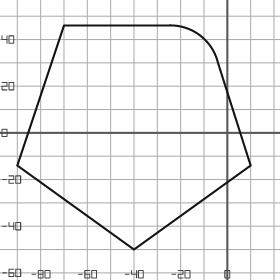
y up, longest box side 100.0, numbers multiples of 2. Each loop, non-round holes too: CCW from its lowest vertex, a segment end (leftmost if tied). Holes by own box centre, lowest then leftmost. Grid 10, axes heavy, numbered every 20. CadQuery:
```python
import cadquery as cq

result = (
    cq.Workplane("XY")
    .moveTo(-40.0, -50.0)
    .lineTo(10.0, -14.0)
    .lineTo(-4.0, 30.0)
    .threePointArc((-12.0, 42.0), (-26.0, 46.0))
    .lineTo(-70.0, 46.0)
    .lineTo(-90.0, -14.0)
    .close()
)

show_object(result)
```